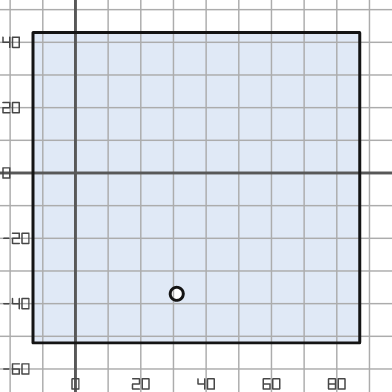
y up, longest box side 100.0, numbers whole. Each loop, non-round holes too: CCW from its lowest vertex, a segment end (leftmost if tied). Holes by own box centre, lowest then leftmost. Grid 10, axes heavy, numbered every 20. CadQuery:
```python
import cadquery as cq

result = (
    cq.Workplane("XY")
    .moveTo(-13.0, -52.0)
    .lineTo(87.0, -52.0)
    .lineTo(87.0, 43.0)
    .lineTo(-13.0, 43.0)
    .close()
    .moveTo(31.0, -37.0)
    .circle(2.0)
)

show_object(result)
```